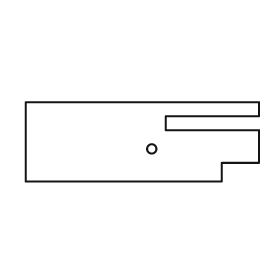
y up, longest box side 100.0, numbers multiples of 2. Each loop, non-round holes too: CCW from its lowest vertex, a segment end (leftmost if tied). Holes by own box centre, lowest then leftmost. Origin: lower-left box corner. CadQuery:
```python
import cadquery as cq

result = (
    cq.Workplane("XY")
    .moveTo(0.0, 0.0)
    .lineTo(84.0, 0.0)
    .lineTo(84.0, 8.0)
    .lineTo(100.0, 8.0)
    .lineTo(100.0, 22.0)
    .lineTo(60.0, 22.0)
    .lineTo(60.0, 28.0)
    .lineTo(100.0, 28.0)
    .lineTo(100.0, 34.0)
    .lineTo(0.0, 34.0)
    .close()
    .moveTo(54.0, 14.0)
    .circle(2.0)
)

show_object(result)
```